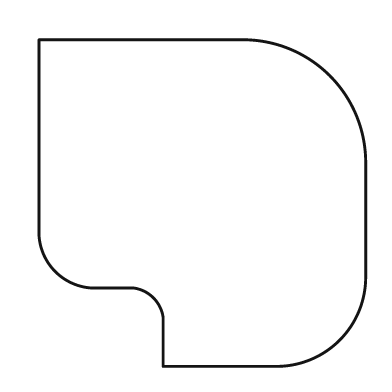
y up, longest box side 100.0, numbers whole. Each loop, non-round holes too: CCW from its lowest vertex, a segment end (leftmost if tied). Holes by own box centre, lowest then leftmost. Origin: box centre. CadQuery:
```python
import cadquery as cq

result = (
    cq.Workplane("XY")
    .moveTo(-12.0, -50.0)
    .lineTo(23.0, -50.0)
    .threePointArc((42.0, -42.0), (50.0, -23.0))
    .lineTo(50.0, 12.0)
    .threePointArc((39.0, 39.0), (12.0, 50.0))
    .lineTo(-50.0, 50.0)
    .lineTo(-50.0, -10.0)
    .threePointArc((-45.0, -21.0), (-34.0, -26.0))
    .lineTo(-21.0, -26.0)
    .threePointArc((-15.0, -29.0), (-12.0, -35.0))
    .close()
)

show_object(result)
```